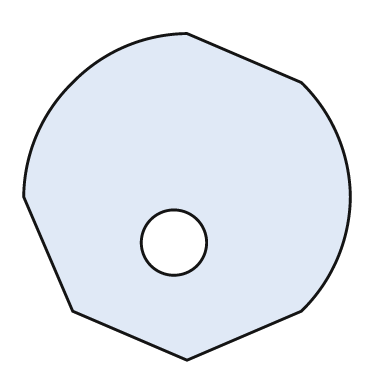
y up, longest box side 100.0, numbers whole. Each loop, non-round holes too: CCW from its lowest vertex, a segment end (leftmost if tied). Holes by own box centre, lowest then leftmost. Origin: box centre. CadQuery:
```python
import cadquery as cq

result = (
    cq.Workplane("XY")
    .moveTo(0.0, -50.0)
    .lineTo(35.0, -35.0)
    .threePointArc((46.0, -19.0), (50.0, 0.0))
    .threePointArc((46.0, 19.0), (35.0, 35.0))
    .lineTo(0.0, 50.0)
    .threePointArc((-19.0, 46.0), (-35.0, 35.0))
    .threePointArc((-46.0, 19.0), (-50.0, 0.0))
    .lineTo(-35.0, -35.0)
    .close()
    .moveTo(-4.0, -14.0)
    .circle(10.0)
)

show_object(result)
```